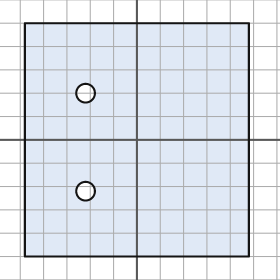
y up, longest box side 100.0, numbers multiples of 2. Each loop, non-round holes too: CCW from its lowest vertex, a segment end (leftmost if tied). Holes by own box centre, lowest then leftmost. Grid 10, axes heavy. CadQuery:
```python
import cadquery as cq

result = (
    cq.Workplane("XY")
    .moveTo(-48.0, -50.0)
    .lineTo(48.0, -50.0)
    .lineTo(48.0, 50.0)
    .lineTo(-48.0, 50.0)
    .close()
    .moveTo(-22.0, -22.0)
    .circle(4.0)
    .moveTo(-22.0, 20.0)
    .circle(4.0)
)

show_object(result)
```